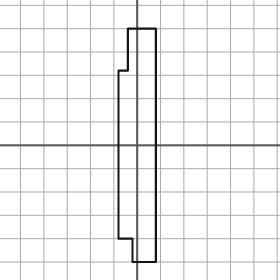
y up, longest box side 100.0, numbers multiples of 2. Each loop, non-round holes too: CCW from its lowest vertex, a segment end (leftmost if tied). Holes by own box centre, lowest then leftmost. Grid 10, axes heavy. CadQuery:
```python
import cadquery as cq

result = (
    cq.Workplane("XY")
    .moveTo(-2.0, -50.0)
    .lineTo(8.0, -50.0)
    .lineTo(8.0, 50.0)
    .lineTo(-4.0, 50.0)
    .lineTo(-4.0, 32.0)
    .lineTo(-8.0, 32.0)
    .lineTo(-8.0, -40.0)
    .lineTo(-2.0, -40.0)
    .close()
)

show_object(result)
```